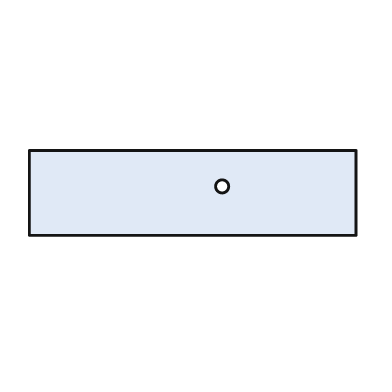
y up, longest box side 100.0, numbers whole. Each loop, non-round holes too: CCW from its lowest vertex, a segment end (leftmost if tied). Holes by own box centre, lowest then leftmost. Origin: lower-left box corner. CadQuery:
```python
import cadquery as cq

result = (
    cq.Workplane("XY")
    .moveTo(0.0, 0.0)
    .lineTo(100.0, 0.0)
    .lineTo(100.0, 26.0)
    .lineTo(0.0, 26.0)
    .close()
    .moveTo(59.0, 15.0)
    .circle(2.0)
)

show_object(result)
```